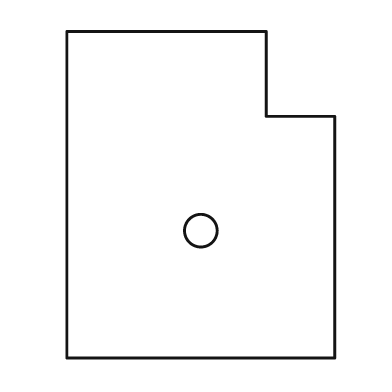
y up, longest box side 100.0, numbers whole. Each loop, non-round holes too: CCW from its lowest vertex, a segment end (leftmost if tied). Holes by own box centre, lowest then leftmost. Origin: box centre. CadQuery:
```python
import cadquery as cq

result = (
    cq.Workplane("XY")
    .moveTo(-41.0, -50.0)
    .lineTo(41.0, -50.0)
    .lineTo(41.0, 24.0)
    .lineTo(20.0, 24.0)
    .lineTo(20.0, 50.0)
    .lineTo(-41.0, 50.0)
    .close()
    .moveTo(0.0, -11.0)
    .circle(5.0)
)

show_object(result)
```